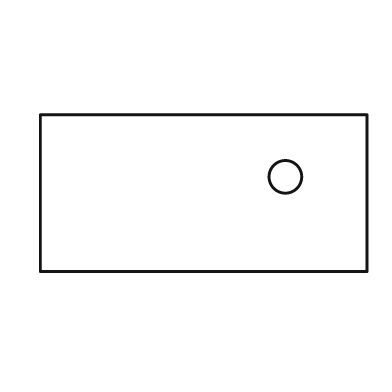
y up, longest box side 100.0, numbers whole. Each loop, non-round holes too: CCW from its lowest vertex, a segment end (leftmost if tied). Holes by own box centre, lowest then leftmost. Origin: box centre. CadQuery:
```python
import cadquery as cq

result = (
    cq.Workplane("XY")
    .moveTo(-50.0, -24.0)
    .lineTo(50.0, -24.0)
    .lineTo(50.0, 24.0)
    .lineTo(-50.0, 24.0)
    .close()
    .moveTo(25.0, 5.0)
    .circle(5.0)
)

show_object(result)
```